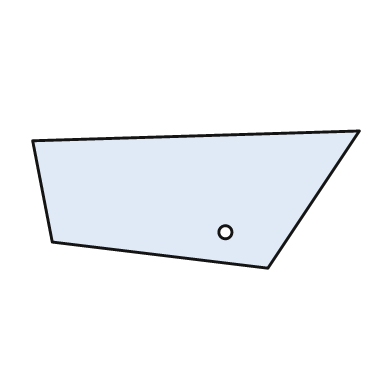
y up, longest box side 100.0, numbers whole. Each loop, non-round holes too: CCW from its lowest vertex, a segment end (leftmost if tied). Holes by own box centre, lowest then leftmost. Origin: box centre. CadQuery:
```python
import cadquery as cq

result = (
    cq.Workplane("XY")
    .moveTo(22.0, -21.0)
    .lineTo(50.0, 21.0)
    .lineTo(-50.0, 18.0)
    .lineTo(-44.0, -13.0)
    .close()
    .moveTo(9.0, -10.0)
    .circle(2.0)
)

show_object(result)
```